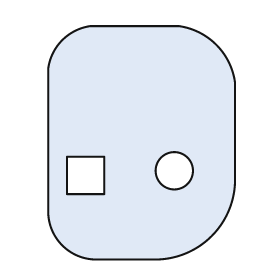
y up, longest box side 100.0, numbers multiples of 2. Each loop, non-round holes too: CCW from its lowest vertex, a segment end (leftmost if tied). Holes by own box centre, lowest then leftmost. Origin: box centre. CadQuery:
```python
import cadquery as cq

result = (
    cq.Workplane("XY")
    .moveTo(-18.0, -50.0)
    .lineTo(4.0, -50.0)
    .threePointArc((30.0, -40.0), (40.0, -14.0))
    .lineTo(40.0, 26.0)
    .threePointArc((32.0, 42.0), (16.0, 50.0))
    .lineTo(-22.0, 50.0)
    .threePointArc((-34.0, 44.0), (-40.0, 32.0))
    .lineTo(-40.0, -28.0)
    .threePointArc((-34.0, -44.0), (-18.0, -50.0))
    .close()
    .moveTo(-32.0, -22.0)
    .lineTo(-16.0, -22.0)
    .lineTo(-16.0, -6.0)
    .lineTo(-32.0, -6.0)
    .close()
    .moveTo(14.0, -12.0)
    .circle(8.0)
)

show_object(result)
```